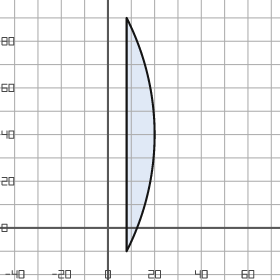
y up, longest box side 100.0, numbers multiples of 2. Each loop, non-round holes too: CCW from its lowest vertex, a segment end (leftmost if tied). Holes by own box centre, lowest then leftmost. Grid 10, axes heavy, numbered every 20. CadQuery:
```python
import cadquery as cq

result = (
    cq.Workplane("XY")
    .moveTo(8.0, -10.0)
    .threePointArc((20.0, 40.0), (8.0, 90.0))
    .close()
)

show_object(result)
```